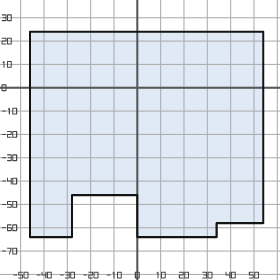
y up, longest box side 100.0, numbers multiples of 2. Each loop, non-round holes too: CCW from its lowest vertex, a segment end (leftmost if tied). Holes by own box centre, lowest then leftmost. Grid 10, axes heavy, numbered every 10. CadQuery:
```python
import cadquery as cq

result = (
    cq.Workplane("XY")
    .moveTo(-46.0, -64.0)
    .lineTo(-28.0, -64.0)
    .lineTo(-28.0, -46.0)
    .lineTo(0.0, -46.0)
    .lineTo(0.0, -64.0)
    .lineTo(34.0, -64.0)
    .lineTo(34.0, -58.0)
    .lineTo(54.0, -58.0)
    .lineTo(54.0, 24.0)
    .lineTo(-46.0, 24.0)
    .close()
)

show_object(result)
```